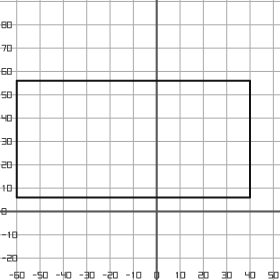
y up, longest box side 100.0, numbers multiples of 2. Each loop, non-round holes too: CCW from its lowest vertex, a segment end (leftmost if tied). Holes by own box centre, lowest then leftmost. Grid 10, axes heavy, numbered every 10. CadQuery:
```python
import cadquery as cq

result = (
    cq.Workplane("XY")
    .moveTo(-60.0, 6.0)
    .lineTo(40.0, 6.0)
    .lineTo(40.0, 56.0)
    .lineTo(-60.0, 56.0)
    .close()
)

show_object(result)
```